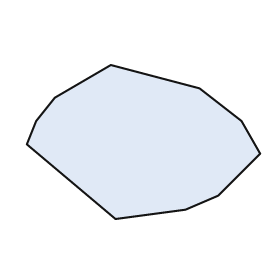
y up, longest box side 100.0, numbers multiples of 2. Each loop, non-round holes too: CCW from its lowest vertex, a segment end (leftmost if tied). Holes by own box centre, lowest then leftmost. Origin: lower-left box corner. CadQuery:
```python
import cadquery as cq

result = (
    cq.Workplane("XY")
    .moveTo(38.0, 0.0)
    .lineTo(68.0, 4.0)
    .lineTo(82.0, 10.0)
    .lineTo(100.0, 28.0)
    .lineTo(92.0, 42.0)
    .lineTo(74.0, 56.0)
    .lineTo(36.0, 66.0)
    .lineTo(12.0, 52.0)
    .lineTo(4.0, 42.0)
    .lineTo(0.0, 32.0)
    .close()
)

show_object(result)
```